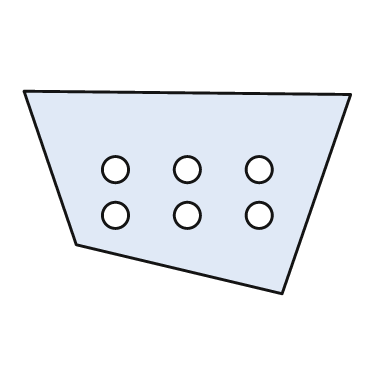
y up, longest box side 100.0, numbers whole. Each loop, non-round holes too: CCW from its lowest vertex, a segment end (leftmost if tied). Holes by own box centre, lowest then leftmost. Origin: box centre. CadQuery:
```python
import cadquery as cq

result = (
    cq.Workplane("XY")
    .moveTo(29.0, -31.0)
    .lineTo(50.0, 30.0)
    .lineTo(-50.0, 31.0)
    .lineTo(-34.0, -16.0)
    .close()
    .moveTo(-22.0, -7.0)
    .circle(4.0)
    .moveTo(0.0, -7.0)
    .circle(4.0)
    .moveTo(22.0, -7.0)
    .circle(4.0)
    .moveTo(-22.0, 7.0)
    .circle(4.0)
    .moveTo(0.0, 7.0)
    .circle(4.0)
    .moveTo(22.0, 7.0)
    .circle(4.0)
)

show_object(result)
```